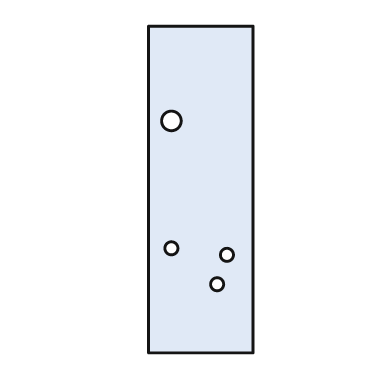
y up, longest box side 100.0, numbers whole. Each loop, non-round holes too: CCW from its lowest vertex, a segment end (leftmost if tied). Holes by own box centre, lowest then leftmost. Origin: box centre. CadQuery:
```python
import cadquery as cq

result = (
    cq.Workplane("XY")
    .moveTo(-16.0, -50.0)
    .lineTo(16.0, -50.0)
    .lineTo(16.0, 50.0)
    .lineTo(-16.0, 50.0)
    .close()
    .moveTo(5.0, -29.0)
    .circle(2.0)
    .moveTo(8.0, -20.0)
    .circle(2.0)
    .moveTo(-9.0, -18.0)
    .circle(2.0)
    .moveTo(-9.0, 21.0)
    .circle(3.0)
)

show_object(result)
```